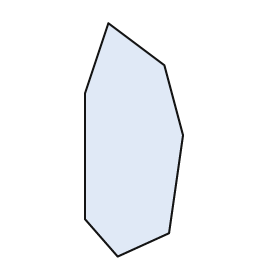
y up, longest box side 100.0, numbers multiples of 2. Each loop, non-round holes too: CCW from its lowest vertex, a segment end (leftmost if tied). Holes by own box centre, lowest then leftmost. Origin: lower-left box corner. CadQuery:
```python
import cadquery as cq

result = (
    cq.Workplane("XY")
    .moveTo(14.0, 0.0)
    .lineTo(36.0, 10.0)
    .lineTo(42.0, 52.0)
    .lineTo(34.0, 82.0)
    .lineTo(10.0, 100.0)
    .lineTo(0.0, 70.0)
    .lineTo(0.0, 16.0)
    .close()
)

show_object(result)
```